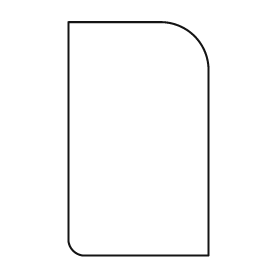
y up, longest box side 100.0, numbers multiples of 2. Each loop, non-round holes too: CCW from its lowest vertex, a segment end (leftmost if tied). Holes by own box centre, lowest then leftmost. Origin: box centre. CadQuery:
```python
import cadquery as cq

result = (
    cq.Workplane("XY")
    .moveTo(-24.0, -50.0)
    .lineTo(30.0, -50.0)
    .lineTo(30.0, 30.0)
    .threePointArc((24.0, 44.0), (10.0, 50.0))
    .lineTo(-30.0, 50.0)
    .lineTo(-30.0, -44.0)
    .threePointArc((-28.0, -48.0), (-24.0, -50.0))
    .close()
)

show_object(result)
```